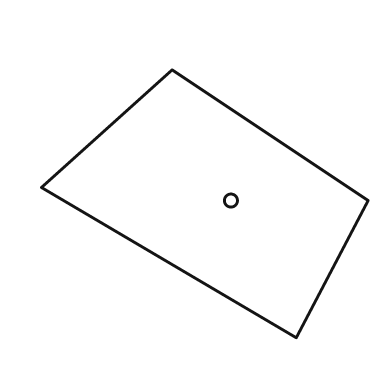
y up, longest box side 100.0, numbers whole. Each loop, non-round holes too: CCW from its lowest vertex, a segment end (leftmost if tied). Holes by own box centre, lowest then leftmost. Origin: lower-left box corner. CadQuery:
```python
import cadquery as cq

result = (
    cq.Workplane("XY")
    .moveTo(78.0, 0.0)
    .lineTo(100.0, 42.0)
    .lineTo(40.0, 82.0)
    .lineTo(0.0, 46.0)
    .close()
    .moveTo(58.0, 42.0)
    .circle(2.0)
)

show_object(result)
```